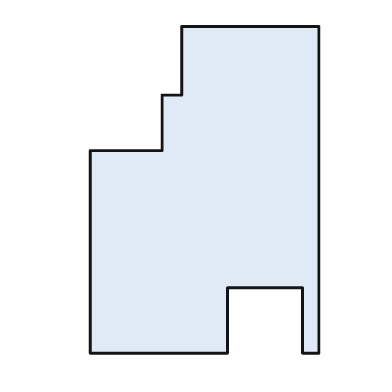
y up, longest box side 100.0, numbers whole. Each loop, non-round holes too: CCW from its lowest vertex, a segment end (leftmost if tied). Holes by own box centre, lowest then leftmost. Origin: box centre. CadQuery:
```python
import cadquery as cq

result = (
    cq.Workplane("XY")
    .moveTo(-35.0, -50.0)
    .lineTo(7.0, -50.0)
    .lineTo(7.0, -30.0)
    .lineTo(30.0, -30.0)
    .lineTo(30.0, -50.0)
    .lineTo(35.0, -50.0)
    .lineTo(35.0, 50.0)
    .lineTo(-7.0, 50.0)
    .lineTo(-7.0, 29.0)
    .lineTo(-13.0, 29.0)
    .lineTo(-13.0, 12.0)
    .lineTo(-35.0, 12.0)
    .close()
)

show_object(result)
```